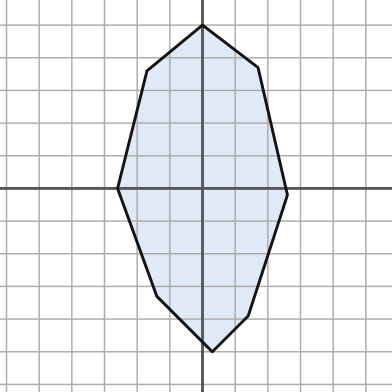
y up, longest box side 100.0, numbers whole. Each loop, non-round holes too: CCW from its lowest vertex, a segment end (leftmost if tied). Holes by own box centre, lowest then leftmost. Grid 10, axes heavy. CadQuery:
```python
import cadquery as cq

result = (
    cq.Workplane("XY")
    .moveTo(3.0, -50.0)
    .lineTo(14.0, -39.0)
    .lineTo(26.0, -2.0)
    .lineTo(17.0, 37.0)
    .lineTo(0.0, 50.0)
    .lineTo(-17.0, 36.0)
    .lineTo(-26.0, 0.0)
    .lineTo(-14.0, -33.0)
    .close()
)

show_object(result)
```